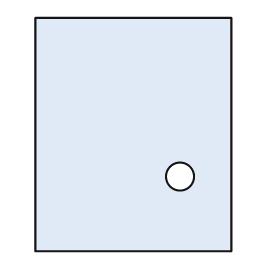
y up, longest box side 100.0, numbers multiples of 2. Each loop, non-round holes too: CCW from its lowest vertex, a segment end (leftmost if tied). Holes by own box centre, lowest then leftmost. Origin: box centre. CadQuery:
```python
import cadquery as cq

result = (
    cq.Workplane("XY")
    .moveTo(-42.0, -50.0)
    .lineTo(42.0, -50.0)
    .lineTo(42.0, 50.0)
    .lineTo(-42.0, 50.0)
    .close()
    .moveTo(20.0, -18.0)
    .circle(6.0)
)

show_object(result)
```